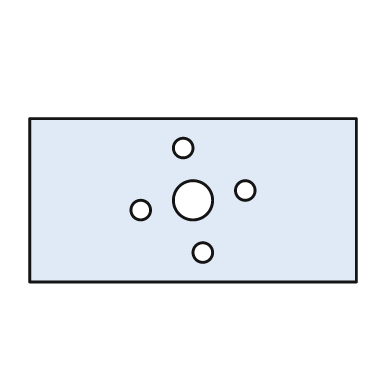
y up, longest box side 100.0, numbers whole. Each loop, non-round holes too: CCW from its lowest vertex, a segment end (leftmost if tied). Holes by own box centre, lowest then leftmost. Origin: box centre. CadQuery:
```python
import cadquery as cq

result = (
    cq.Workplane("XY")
    .moveTo(-50.0, -25.0)
    .lineTo(50.0, -25.0)
    .lineTo(50.0, 25.0)
    .lineTo(-50.0, 25.0)
    .close()
    .moveTo(3.0, -16.0)
    .circle(3.0)
    .moveTo(-16.0, -3.0)
    .circle(3.0)
    .moveTo(0.0, 0.0)
    .circle(6.0)
    .moveTo(16.0, 3.0)
    .circle(3.0)
    .moveTo(-3.0, 16.0)
    .circle(3.0)
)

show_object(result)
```